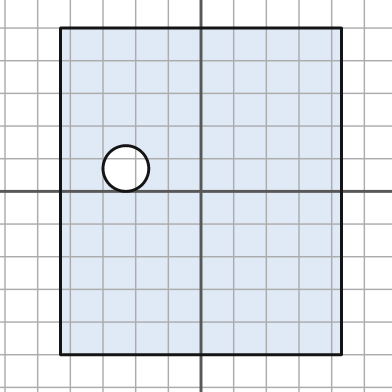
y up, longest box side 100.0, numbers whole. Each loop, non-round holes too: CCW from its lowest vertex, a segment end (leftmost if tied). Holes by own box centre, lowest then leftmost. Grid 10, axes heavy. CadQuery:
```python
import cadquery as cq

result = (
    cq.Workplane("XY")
    .moveTo(-43.0, -50.0)
    .lineTo(43.0, -50.0)
    .lineTo(43.0, 50.0)
    .lineTo(-43.0, 50.0)
    .close()
    .moveTo(-23.0, 7.0)
    .circle(7.0)
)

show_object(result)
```